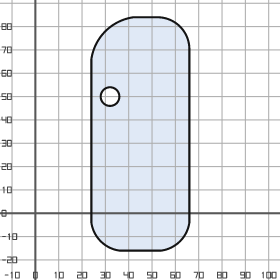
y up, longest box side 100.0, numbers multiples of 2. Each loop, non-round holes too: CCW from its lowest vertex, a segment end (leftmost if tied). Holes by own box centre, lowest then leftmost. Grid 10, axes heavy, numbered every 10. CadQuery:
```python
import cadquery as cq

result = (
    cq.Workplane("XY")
    .moveTo(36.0, -16.0)
    .lineTo(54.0, -16.0)
    .threePointArc((62.0, -12.0), (66.0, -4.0))
    .lineTo(66.0, 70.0)
    .threePointArc((62.0, 80.0), (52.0, 84.0))
    .lineTo(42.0, 84.0)
    .threePointArc((30.0, 78.0), (24.0, 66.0))
    .lineTo(24.0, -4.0)
    .threePointArc((28.0, -12.0), (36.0, -16.0))
    .close()
    .moveTo(32.0, 50.0)
    .circle(4.0)
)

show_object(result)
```